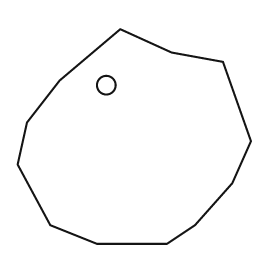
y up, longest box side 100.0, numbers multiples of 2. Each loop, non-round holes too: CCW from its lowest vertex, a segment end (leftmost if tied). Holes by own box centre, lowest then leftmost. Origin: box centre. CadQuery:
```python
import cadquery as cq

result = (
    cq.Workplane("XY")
    .moveTo(-16.0, -46.0)
    .lineTo(14.0, -46.0)
    .lineTo(26.0, -38.0)
    .lineTo(42.0, -20.0)
    .lineTo(50.0, -2.0)
    .lineTo(38.0, 32.0)
    .lineTo(16.0, 36.0)
    .lineTo(-6.0, 46.0)
    .lineTo(-32.0, 24.0)
    .lineTo(-46.0, 6.0)
    .lineTo(-50.0, -12.0)
    .lineTo(-36.0, -38.0)
    .close()
    .moveTo(-12.0, 22.0)
    .circle(4.0)
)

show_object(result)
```